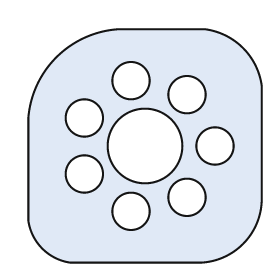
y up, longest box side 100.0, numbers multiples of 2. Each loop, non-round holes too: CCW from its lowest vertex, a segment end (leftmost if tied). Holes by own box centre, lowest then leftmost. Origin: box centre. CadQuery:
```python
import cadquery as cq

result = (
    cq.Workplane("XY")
    .moveTo(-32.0, -50.0)
    .lineTo(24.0, -50.0)
    .threePointArc((42.0, -42.0), (50.0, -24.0))
    .lineTo(50.0, 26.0)
    .threePointArc((42.0, 42.0), (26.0, 50.0))
    .lineTo(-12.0, 50.0)
    .threePointArc((-38.0, 38.0), (-50.0, 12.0))
    .lineTo(-50.0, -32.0)
    .threePointArc((-44.0, -44.0), (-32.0, -50.0))
    .close()
    .moveTo(-6.0, -28.0)
    .circle(8.0)
    .moveTo(18.0, -22.0)
    .circle(8.0)
    .moveTo(-26.0, -12.0)
    .circle(8.0)
    .moveTo(0.0, 0.0)
    .circle(16.0)
    .moveTo(30.0, 0.0)
    .circle(8.0)
    .moveTo(-26.0, 12.0)
    .circle(8.0)
    .moveTo(18.0, 22.0)
    .circle(8.0)
    .moveTo(-6.0, 28.0)
    .circle(8.0)
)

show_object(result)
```